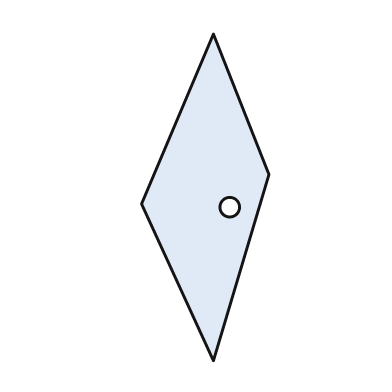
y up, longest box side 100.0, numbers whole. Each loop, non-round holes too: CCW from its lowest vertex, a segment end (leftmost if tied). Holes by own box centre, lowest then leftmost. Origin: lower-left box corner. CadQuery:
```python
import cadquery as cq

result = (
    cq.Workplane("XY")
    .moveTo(22.0, 0.0)
    .lineTo(39.0, 57.0)
    .lineTo(22.0, 100.0)
    .lineTo(0.0, 48.0)
    .close()
    .moveTo(27.0, 47.0)
    .circle(3.0)
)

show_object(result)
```